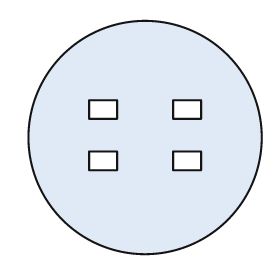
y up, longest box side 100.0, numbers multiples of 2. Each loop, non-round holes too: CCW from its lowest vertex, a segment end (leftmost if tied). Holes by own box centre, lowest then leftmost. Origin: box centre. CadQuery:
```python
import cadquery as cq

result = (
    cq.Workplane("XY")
    .moveTo(0.0, 0.0)
    .circle(50.0)
    .moveTo(-24.0, -14.0)
    .lineTo(-12.0, -14.0)
    .lineTo(-12.0, -6.0)
    .lineTo(-24.0, -6.0)
    .close()
    .moveTo(12.0, -14.0)
    .lineTo(24.0, -14.0)
    .lineTo(24.0, -6.0)
    .lineTo(12.0, -6.0)
    .close()
    .moveTo(-24.0, 8.0)
    .lineTo(-12.0, 8.0)
    .lineTo(-12.0, 16.0)
    .lineTo(-24.0, 16.0)
    .close()
    .moveTo(12.0, 8.0)
    .lineTo(24.0, 8.0)
    .lineTo(24.0, 16.0)
    .lineTo(12.0, 16.0)
    .close()
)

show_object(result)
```